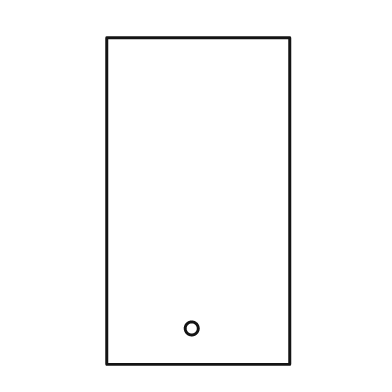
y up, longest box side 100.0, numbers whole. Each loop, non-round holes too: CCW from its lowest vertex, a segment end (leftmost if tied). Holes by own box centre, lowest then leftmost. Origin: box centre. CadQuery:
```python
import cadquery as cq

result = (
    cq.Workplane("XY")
    .moveTo(-28.0, -50.0)
    .lineTo(28.0, -50.0)
    .lineTo(28.0, 50.0)
    .lineTo(-28.0, 50.0)
    .close()
    .moveTo(-2.0, -39.0)
    .circle(2.0)
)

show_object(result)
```